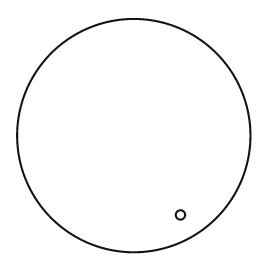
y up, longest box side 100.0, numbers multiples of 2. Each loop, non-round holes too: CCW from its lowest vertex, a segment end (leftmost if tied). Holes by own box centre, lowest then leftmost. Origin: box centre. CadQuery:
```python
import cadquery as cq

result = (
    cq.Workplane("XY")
    .moveTo(0.0, 0.0)
    .circle(50.0)
    .moveTo(20.0, -34.0)
    .circle(2.0)
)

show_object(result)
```